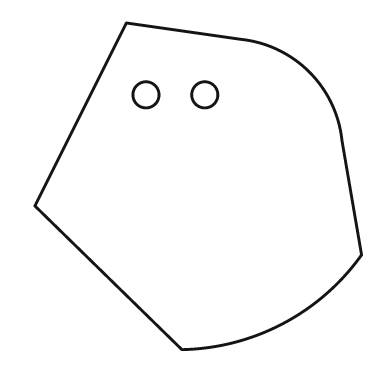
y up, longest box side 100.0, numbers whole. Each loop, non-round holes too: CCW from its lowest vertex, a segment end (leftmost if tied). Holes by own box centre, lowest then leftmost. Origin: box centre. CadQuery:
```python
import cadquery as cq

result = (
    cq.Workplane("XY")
    .moveTo(-5.0, -50.0)
    .threePointArc((26.0, -42.0), (50.0, -21.0))
    .lineTo(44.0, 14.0)
    .threePointArc((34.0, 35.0), (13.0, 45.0))
    .lineTo(-22.0, 50.0)
    .lineTo(-50.0, -6.0)
    .close()
    .moveTo(-16.0, 28.0)
    .circle(4.0)
    .moveTo(2.0, 28.0)
    .circle(4.0)
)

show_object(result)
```